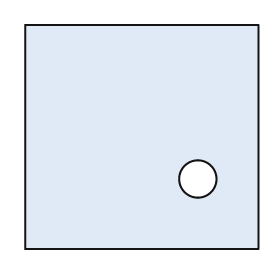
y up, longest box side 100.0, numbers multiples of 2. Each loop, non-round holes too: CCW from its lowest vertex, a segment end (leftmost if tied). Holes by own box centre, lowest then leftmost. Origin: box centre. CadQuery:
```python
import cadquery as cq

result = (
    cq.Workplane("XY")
    .moveTo(-50.0, -48.0)
    .lineTo(50.0, -48.0)
    .lineTo(50.0, 48.0)
    .lineTo(-50.0, 48.0)
    .close()
    .moveTo(24.0, -18.0)
    .circle(8.0)
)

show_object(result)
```